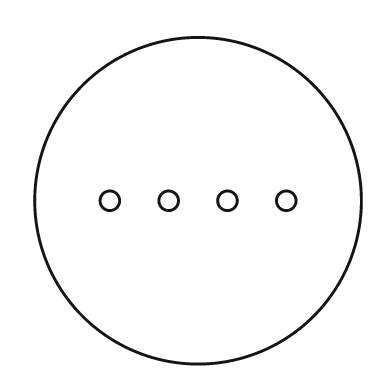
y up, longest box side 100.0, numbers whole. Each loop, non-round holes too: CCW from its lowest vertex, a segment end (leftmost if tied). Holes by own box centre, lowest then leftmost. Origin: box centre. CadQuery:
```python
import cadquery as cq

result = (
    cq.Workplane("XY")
    .moveTo(0.0, 0.0)
    .circle(50.0)
    .moveTo(-27.0, 0.0)
    .circle(3.0)
    .moveTo(-9.0, 0.0)
    .circle(3.0)
    .moveTo(9.0, 0.0)
    .circle(3.0)
    .moveTo(27.0, 0.0)
    .circle(3.0)
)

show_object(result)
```